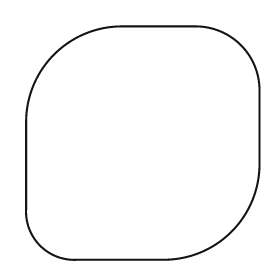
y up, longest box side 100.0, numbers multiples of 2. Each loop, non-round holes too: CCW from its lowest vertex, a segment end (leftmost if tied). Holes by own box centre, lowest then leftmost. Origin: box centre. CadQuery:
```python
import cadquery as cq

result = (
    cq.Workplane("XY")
    .moveTo(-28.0, -50.0)
    .lineTo(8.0, -50.0)
    .threePointArc((38.0, -38.0), (50.0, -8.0))
    .lineTo(50.0, 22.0)
    .threePointArc((42.0, 42.0), (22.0, 50.0))
    .lineTo(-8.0, 50.0)
    .threePointArc((-38.0, 38.0), (-50.0, 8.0))
    .lineTo(-50.0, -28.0)
    .threePointArc((-44.0, -44.0), (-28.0, -50.0))
    .close()
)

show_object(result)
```